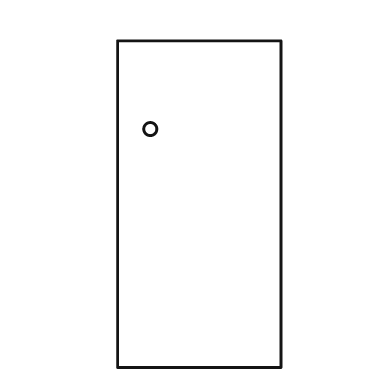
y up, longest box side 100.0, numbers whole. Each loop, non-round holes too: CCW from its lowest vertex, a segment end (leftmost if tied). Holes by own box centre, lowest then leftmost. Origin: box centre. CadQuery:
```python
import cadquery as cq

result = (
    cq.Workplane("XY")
    .moveTo(-25.0, -50.0)
    .lineTo(25.0, -50.0)
    .lineTo(25.0, 50.0)
    .lineTo(-25.0, 50.0)
    .close()
    .moveTo(-15.0, 23.0)
    .circle(2.0)
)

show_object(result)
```